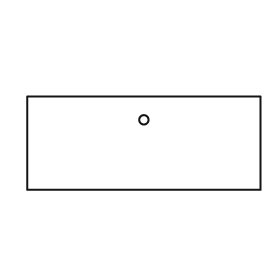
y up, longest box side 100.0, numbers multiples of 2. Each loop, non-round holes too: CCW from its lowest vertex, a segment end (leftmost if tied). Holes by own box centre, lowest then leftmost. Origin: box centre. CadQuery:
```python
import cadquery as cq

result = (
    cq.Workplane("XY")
    .moveTo(-50.0, -20.0)
    .lineTo(50.0, -20.0)
    .lineTo(50.0, 20.0)
    .lineTo(-50.0, 20.0)
    .close()
    .moveTo(0.0, 10.0)
    .circle(2.0)
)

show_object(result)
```